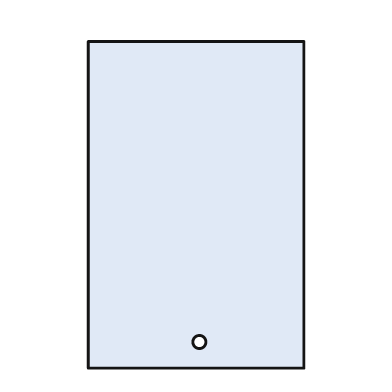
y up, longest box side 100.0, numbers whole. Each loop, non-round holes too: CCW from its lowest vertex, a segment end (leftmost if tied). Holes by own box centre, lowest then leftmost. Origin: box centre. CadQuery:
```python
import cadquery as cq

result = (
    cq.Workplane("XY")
    .moveTo(-33.0, -50.0)
    .lineTo(33.0, -50.0)
    .lineTo(33.0, 50.0)
    .lineTo(-33.0, 50.0)
    .close()
    .moveTo(1.0, -42.0)
    .circle(2.0)
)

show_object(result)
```